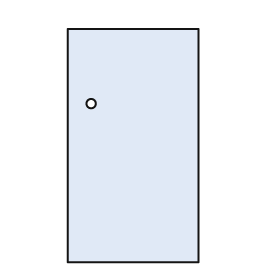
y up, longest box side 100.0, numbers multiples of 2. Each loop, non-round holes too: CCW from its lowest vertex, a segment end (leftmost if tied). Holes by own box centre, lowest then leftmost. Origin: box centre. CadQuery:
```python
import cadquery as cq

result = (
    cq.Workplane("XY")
    .moveTo(-28.0, -50.0)
    .lineTo(28.0, -50.0)
    .lineTo(28.0, 50.0)
    .lineTo(-28.0, 50.0)
    .close()
    .moveTo(-18.0, 18.0)
    .circle(2.0)
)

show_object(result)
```